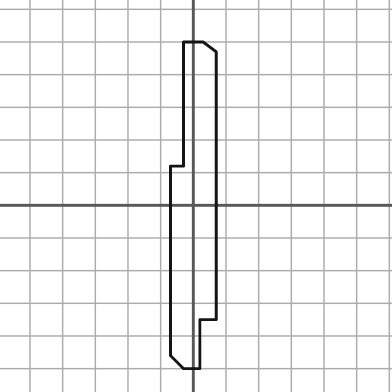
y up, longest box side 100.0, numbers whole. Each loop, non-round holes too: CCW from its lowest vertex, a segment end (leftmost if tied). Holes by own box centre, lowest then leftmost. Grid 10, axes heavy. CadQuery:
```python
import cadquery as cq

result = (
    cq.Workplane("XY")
    .moveTo(-3.0, -50.0)
    .lineTo(2.0, -50.0)
    .lineTo(2.0, -35.0)
    .lineTo(7.0, -35.0)
    .lineTo(7.0, 47.0)
    .lineTo(3.0, 50.0)
    .lineTo(-3.0, 50.0)
    .lineTo(-3.0, 12.0)
    .lineTo(-7.0, 12.0)
    .lineTo(-7.0, -46.0)
    .close()
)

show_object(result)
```